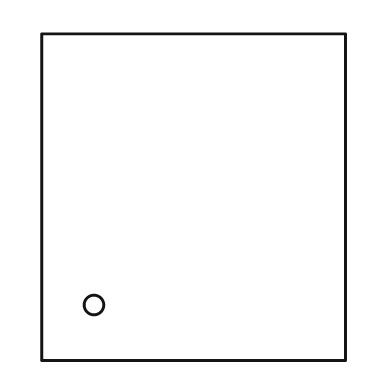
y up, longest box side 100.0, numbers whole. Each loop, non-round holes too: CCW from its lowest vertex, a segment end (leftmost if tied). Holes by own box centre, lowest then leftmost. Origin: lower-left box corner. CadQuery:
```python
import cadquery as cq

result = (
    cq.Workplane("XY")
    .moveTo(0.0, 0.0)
    .lineTo(93.0, 0.0)
    .lineTo(93.0, 100.0)
    .lineTo(0.0, 100.0)
    .close()
    .moveTo(16.0, 17.0)
    .circle(3.0)
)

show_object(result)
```